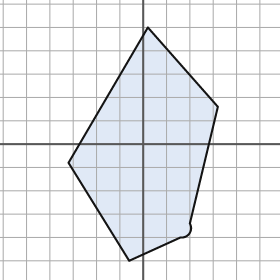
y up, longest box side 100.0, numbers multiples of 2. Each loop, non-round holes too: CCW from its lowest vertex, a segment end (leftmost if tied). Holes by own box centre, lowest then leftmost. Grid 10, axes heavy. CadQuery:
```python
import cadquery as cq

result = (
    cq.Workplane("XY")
    .moveTo(-6.0, -50.0)
    .lineTo(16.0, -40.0)
    .threePointArc((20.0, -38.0), (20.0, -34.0))
    .lineTo(32.0, 16.0)
    .lineTo(2.0, 50.0)
    .lineTo(-32.0, -8.0)
    .close()
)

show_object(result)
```